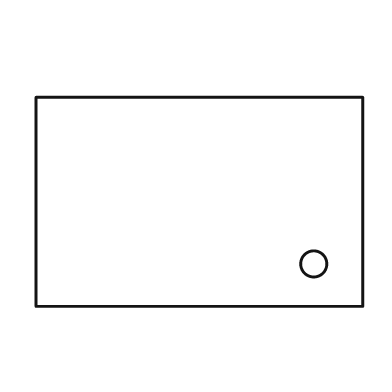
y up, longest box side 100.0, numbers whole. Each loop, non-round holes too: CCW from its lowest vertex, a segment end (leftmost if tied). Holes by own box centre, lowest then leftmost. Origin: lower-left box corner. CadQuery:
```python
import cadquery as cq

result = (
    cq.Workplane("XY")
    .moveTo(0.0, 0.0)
    .lineTo(100.0, 0.0)
    .lineTo(100.0, 64.0)
    .lineTo(0.0, 64.0)
    .close()
    .moveTo(85.0, 13.0)
    .circle(4.0)
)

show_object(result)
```